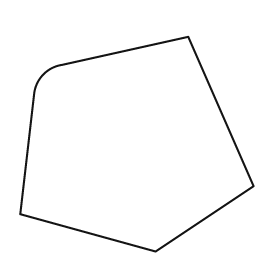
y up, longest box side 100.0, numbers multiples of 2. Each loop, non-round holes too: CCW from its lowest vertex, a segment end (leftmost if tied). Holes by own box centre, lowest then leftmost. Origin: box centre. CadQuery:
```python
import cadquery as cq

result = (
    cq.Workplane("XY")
    .moveTo(8.0, -46.0)
    .lineTo(50.0, -18.0)
    .lineTo(22.0, 46.0)
    .lineTo(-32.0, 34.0)
    .threePointArc((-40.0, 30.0), (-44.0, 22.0))
    .lineTo(-50.0, -30.0)
    .close()
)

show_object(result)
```